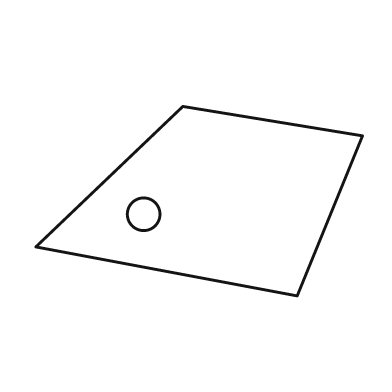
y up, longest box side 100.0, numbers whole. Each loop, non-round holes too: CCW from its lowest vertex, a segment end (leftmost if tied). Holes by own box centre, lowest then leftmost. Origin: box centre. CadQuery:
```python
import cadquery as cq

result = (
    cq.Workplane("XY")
    .moveTo(30.0, -29.0)
    .lineTo(50.0, 20.0)
    .lineTo(-5.0, 29.0)
    .lineTo(-50.0, -14.0)
    .close()
    .moveTo(-17.0, -4.0)
    .circle(5.0)
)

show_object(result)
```